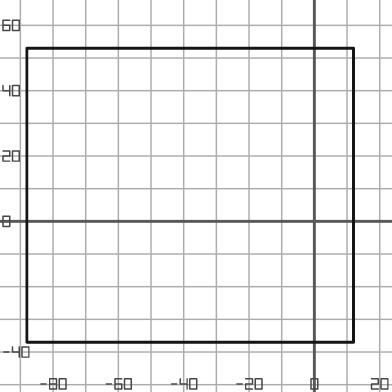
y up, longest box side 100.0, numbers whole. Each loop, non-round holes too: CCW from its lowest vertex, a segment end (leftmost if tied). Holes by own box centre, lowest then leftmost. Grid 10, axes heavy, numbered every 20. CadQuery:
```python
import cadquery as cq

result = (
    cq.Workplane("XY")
    .moveTo(-88.0, -37.0)
    .lineTo(12.0, -37.0)
    .lineTo(12.0, 53.0)
    .lineTo(-88.0, 53.0)
    .close()
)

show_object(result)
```